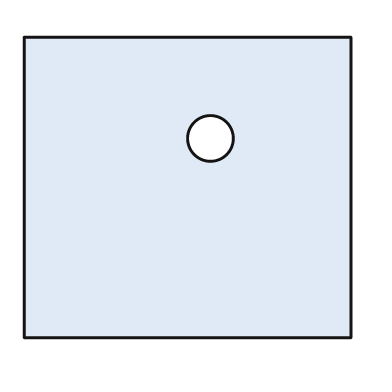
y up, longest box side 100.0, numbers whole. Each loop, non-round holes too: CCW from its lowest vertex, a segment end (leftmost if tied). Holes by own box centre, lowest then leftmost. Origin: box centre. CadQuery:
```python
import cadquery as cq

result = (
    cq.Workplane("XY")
    .moveTo(-50.0, -46.0)
    .lineTo(50.0, -46.0)
    .lineTo(50.0, 46.0)
    .lineTo(-50.0, 46.0)
    .close()
    .moveTo(7.0, 15.0)
    .circle(7.0)
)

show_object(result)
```